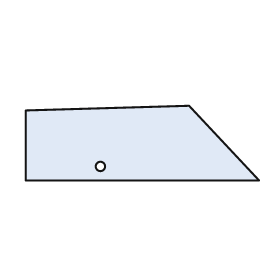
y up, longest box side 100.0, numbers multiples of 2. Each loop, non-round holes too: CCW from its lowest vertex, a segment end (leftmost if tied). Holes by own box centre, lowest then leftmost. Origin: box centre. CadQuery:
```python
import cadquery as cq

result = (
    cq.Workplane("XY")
    .moveTo(-50.0, -16.0)
    .lineTo(50.0, -16.0)
    .lineTo(20.0, 16.0)
    .lineTo(-50.0, 14.0)
    .close()
    .moveTo(-18.0, -10.0)
    .circle(2.0)
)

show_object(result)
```